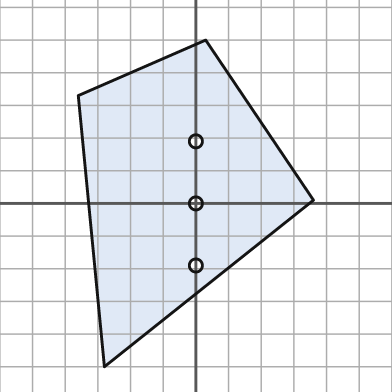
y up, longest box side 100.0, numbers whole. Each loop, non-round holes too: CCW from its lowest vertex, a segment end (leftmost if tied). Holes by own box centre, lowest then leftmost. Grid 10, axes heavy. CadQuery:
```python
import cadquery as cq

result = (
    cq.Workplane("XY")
    .moveTo(-28.0, -50.0)
    .lineTo(36.0, 1.0)
    .lineTo(3.0, 50.0)
    .lineTo(-36.0, 33.0)
    .close()
    .moveTo(0.0, -19.0)
    .circle(2.0)
    .moveTo(0.0, 0.0)
    .circle(2.0)
    .moveTo(0.0, 19.0)
    .circle(2.0)
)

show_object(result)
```